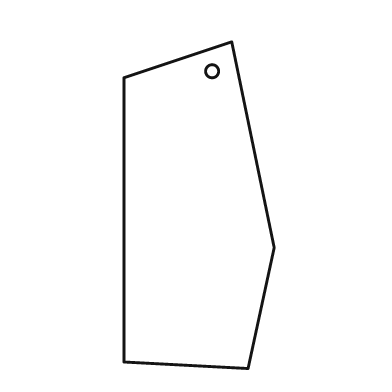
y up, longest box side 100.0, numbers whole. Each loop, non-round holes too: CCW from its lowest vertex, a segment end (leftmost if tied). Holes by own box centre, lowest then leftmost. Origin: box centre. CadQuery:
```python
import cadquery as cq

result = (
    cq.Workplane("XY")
    .moveTo(15.0, -50.0)
    .lineTo(23.0, -13.0)
    .lineTo(10.0, 50.0)
    .lineTo(-23.0, 39.0)
    .lineTo(-23.0, -48.0)
    .close()
    .moveTo(4.0, 41.0)
    .circle(2.0)
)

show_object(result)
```